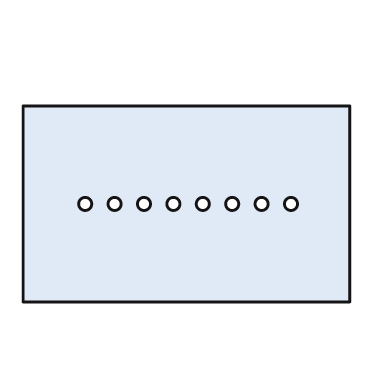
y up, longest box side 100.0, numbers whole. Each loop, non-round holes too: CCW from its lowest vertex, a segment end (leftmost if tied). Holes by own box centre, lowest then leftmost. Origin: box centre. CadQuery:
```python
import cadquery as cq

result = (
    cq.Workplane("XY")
    .moveTo(-50.0, -30.0)
    .lineTo(50.0, -30.0)
    .lineTo(50.0, 30.0)
    .lineTo(-50.0, 30.0)
    .close()
    .moveTo(-31.0, 0.0)
    .circle(2.0)
    .moveTo(-22.0, 0.0)
    .circle(2.0)
    .moveTo(-13.0, 0.0)
    .circle(2.0)
    .moveTo(-4.0, 0.0)
    .circle(2.0)
    .moveTo(5.0, 0.0)
    .circle(2.0)
    .moveTo(14.0, 0.0)
    .circle(2.0)
    .moveTo(23.0, 0.0)
    .circle(2.0)
    .moveTo(32.0, 0.0)
    .circle(2.0)
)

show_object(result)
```